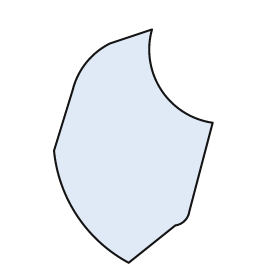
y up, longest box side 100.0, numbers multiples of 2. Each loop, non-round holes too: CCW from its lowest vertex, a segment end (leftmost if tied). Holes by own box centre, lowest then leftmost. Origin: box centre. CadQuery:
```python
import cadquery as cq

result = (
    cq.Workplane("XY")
    .moveTo(-2.0, -50.0)
    .lineTo(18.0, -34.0)
    .threePointArc((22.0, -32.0), (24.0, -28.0))
    .lineTo(34.0, 10.0)
    .threePointArc((12.0, 24.0), (8.0, 50.0))
    .lineTo(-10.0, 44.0)
    .threePointArc((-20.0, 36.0), (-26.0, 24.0))
    .lineTo(-34.0, -2.0)
    .threePointArc((-24.0, -30.0), (-2.0, -50.0))
    .close()
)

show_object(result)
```